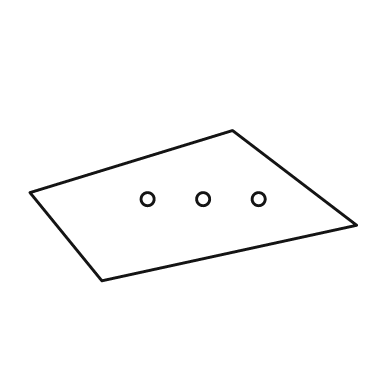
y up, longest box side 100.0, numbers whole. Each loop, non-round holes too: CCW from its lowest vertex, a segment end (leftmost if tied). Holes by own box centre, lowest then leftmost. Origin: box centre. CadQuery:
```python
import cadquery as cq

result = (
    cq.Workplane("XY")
    .moveTo(-28.0, -23.0)
    .lineTo(50.0, -6.0)
    .lineTo(12.0, 23.0)
    .lineTo(-50.0, 4.0)
    .close()
    .moveTo(-14.0, 2.0)
    .circle(2.0)
    .moveTo(3.0, 2.0)
    .circle(2.0)
    .moveTo(20.0, 2.0)
    .circle(2.0)
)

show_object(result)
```